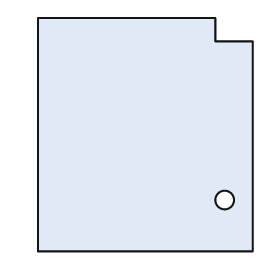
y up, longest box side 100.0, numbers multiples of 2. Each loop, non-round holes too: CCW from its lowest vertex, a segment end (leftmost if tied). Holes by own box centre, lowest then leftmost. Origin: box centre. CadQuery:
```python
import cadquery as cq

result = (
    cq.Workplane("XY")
    .moveTo(-46.0, -50.0)
    .lineTo(46.0, -50.0)
    .lineTo(46.0, 40.0)
    .lineTo(30.0, 40.0)
    .lineTo(30.0, 50.0)
    .lineTo(-46.0, 50.0)
    .close()
    .moveTo(34.0, -28.0)
    .circle(4.0)
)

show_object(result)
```